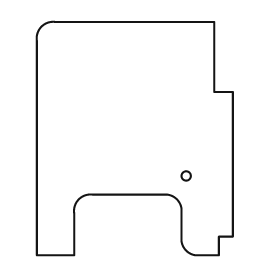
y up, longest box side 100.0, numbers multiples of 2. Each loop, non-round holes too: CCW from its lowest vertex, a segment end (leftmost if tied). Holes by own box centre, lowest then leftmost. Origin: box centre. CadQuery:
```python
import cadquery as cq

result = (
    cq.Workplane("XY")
    .moveTo(-42.0, -50.0)
    .lineTo(-26.0, -50.0)
    .lineTo(-26.0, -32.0)
    .threePointArc((-24.0, -26.0), (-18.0, -24.0))
    .lineTo(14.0, -24.0)
    .threePointArc((18.0, -26.0), (20.0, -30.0))
    .lineTo(20.0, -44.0)
    .threePointArc((22.0, -48.0), (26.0, -50.0))
    .lineTo(36.0, -50.0)
    .lineTo(36.0, -42.0)
    .lineTo(42.0, -42.0)
    .lineTo(42.0, 20.0)
    .lineTo(34.0, 20.0)
    .lineTo(34.0, 50.0)
    .lineTo(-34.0, 50.0)
    .threePointArc((-40.0, 48.0), (-42.0, 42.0))
    .close()
    .moveTo(22.0, -16.0)
    .circle(2.0)
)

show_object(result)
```